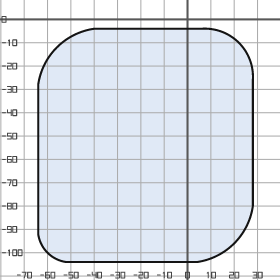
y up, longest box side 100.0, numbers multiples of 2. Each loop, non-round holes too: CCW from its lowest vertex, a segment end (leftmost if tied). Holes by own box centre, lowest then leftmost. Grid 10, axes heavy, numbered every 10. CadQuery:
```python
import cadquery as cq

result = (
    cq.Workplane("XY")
    .moveTo(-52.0, -104.0)
    .lineTo(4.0, -104.0)
    .threePointArc((20.0, -96.0), (28.0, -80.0))
    .lineTo(28.0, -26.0)
    .threePointArc((22.0, -10.0), (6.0, -4.0))
    .lineTo(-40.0, -4.0)
    .threePointArc((-56.0, -12.0), (-64.0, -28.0))
    .lineTo(-64.0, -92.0)
    .threePointArc((-60.0, -100.0), (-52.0, -104.0))
    .close()
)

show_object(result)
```